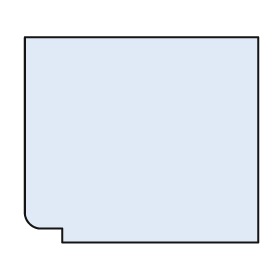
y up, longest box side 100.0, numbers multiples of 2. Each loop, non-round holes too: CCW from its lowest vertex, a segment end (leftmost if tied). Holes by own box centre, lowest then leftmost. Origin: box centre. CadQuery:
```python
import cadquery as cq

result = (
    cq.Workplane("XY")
    .moveTo(-34.0, -44.0)
    .lineTo(50.0, -44.0)
    .lineTo(50.0, 44.0)
    .lineTo(-50.0, 44.0)
    .lineTo(-50.0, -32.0)
    .threePointArc((-48.0, -36.0), (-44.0, -38.0))
    .lineTo(-34.0, -38.0)
    .close()
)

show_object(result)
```